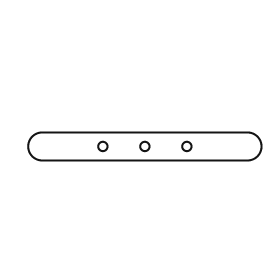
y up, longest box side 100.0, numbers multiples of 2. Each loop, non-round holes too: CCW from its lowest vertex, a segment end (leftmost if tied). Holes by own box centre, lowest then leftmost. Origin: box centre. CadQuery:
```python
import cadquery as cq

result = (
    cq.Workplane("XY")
    .moveTo(-44.0, -6.0)
    .lineTo(44.0, -6.0)
    .threePointArc((50.0, 0.0), (44.0, 6.0))
    .lineTo(-44.0, 6.0)
    .threePointArc((-50.0, 0.0), (-44.0, -6.0))
    .close()
    .moveTo(-18.0, 0.0)
    .circle(2.0)
    .moveTo(0.0, 0.0)
    .circle(2.0)
    .moveTo(18.0, 0.0)
    .circle(2.0)
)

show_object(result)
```